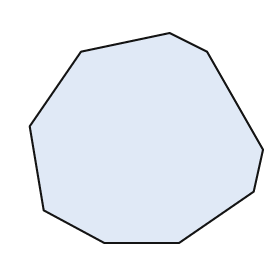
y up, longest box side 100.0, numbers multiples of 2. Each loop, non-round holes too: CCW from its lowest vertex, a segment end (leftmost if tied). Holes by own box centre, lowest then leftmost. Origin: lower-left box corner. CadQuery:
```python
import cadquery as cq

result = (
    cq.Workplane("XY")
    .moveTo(32.0, 0.0)
    .lineTo(64.0, 0.0)
    .lineTo(96.0, 22.0)
    .lineTo(100.0, 40.0)
    .lineTo(76.0, 82.0)
    .lineTo(60.0, 90.0)
    .lineTo(22.0, 82.0)
    .lineTo(0.0, 50.0)
    .lineTo(6.0, 14.0)
    .close()
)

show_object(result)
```